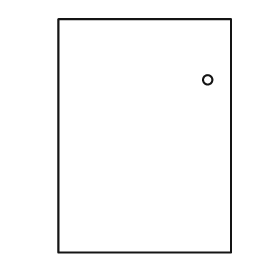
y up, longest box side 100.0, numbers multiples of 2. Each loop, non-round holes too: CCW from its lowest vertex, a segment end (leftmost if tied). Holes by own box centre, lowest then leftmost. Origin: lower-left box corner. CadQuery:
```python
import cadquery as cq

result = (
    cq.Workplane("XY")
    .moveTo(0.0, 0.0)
    .lineTo(74.0, 0.0)
    .lineTo(74.0, 100.0)
    .lineTo(0.0, 100.0)
    .close()
    .moveTo(64.0, 74.0)
    .circle(2.0)
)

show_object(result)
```